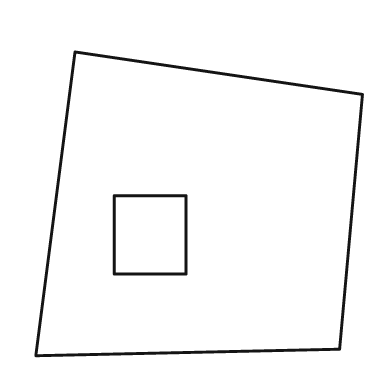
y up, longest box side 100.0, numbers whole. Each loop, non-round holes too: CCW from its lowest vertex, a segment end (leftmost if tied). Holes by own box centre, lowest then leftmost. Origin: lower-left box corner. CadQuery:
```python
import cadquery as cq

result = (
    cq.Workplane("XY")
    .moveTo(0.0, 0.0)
    .lineTo(93.0, 2.0)
    .lineTo(100.0, 80.0)
    .lineTo(12.0, 93.0)
    .close()
    .moveTo(24.0, 25.0)
    .lineTo(46.0, 25.0)
    .lineTo(46.0, 49.0)
    .lineTo(24.0, 49.0)
    .close()
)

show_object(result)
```